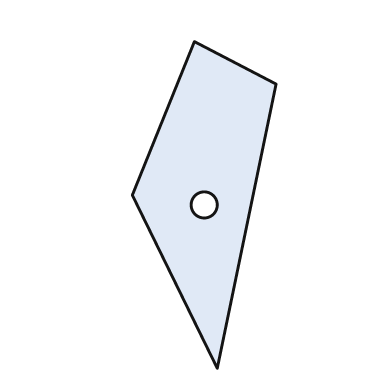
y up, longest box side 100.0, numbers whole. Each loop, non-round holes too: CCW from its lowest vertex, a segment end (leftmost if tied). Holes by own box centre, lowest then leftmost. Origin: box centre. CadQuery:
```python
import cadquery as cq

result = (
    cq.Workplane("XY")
    .moveTo(4.0, -50.0)
    .lineTo(22.0, 37.0)
    .lineTo(-3.0, 50.0)
    .lineTo(-22.0, 3.0)
    .close()
    .moveTo(0.0, 0.0)
    .circle(4.0)
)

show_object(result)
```